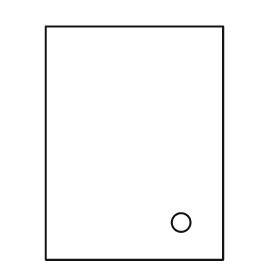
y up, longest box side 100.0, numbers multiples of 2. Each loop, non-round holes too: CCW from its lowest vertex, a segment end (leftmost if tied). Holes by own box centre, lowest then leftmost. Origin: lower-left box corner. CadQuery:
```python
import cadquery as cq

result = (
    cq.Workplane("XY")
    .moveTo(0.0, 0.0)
    .lineTo(76.0, 0.0)
    .lineTo(76.0, 100.0)
    .lineTo(0.0, 100.0)
    .close()
    .moveTo(58.0, 16.0)
    .circle(4.0)
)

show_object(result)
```